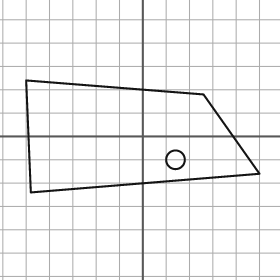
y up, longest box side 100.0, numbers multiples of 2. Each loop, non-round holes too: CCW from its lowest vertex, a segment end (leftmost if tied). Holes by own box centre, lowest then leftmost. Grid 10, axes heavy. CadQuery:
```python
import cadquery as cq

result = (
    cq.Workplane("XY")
    .moveTo(-48.0, -24.0)
    .lineTo(50.0, -16.0)
    .lineTo(26.0, 18.0)
    .lineTo(-50.0, 24.0)
    .close()
    .moveTo(14.0, -10.0)
    .circle(4.0)
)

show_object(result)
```